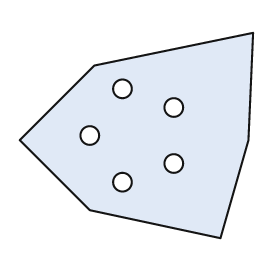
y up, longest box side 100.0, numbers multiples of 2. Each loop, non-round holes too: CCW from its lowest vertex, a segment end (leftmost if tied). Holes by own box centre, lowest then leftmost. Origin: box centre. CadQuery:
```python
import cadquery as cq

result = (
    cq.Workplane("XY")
    .moveTo(36.0, -44.0)
    .lineTo(48.0, -2.0)
    .lineTo(50.0, 44.0)
    .lineTo(-18.0, 30.0)
    .lineTo(-50.0, -2.0)
    .lineTo(-20.0, -32.0)
    .close()
    .moveTo(-6.0, -20.0)
    .circle(4.0)
    .moveTo(16.0, -12.0)
    .circle(4.0)
    .moveTo(-20.0, 0.0)
    .circle(4.0)
    .moveTo(16.0, 12.0)
    .circle(4.0)
    .moveTo(-6.0, 20.0)
    .circle(4.0)
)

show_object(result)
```